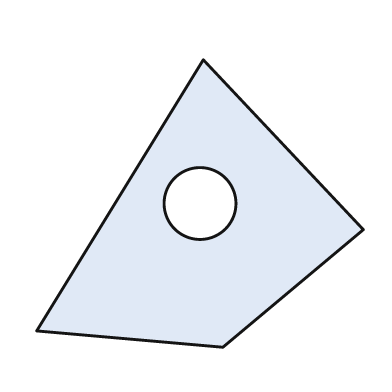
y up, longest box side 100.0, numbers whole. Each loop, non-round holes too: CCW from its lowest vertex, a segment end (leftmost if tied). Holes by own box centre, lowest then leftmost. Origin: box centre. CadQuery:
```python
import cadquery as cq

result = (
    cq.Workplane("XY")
    .moveTo(7.0, -44.0)
    .lineTo(50.0, -8.0)
    .lineTo(1.0, 44.0)
    .lineTo(-50.0, -39.0)
    .close()
    .moveTo(0.0, 0.0)
    .circle(11.0)
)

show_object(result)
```